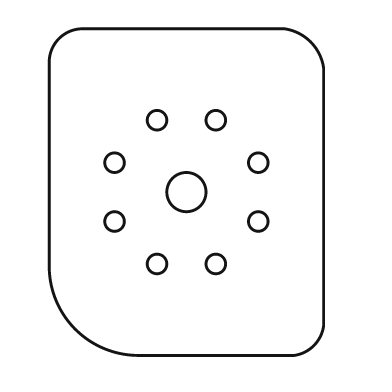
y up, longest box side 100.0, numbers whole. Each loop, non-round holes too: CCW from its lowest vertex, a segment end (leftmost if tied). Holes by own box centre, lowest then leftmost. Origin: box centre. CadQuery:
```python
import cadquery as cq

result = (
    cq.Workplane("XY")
    .moveTo(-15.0, -50.0)
    .lineTo(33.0, -50.0)
    .threePointArc((39.0, -47.0), (42.0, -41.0))
    .lineTo(42.0, 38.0)
    .threePointArc((38.0, 46.0), (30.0, 50.0))
    .lineTo(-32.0, 50.0)
    .threePointArc((-39.0, 47.0), (-42.0, 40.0))
    .lineTo(-42.0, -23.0)
    .threePointArc((-34.0, -42.0), (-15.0, -50.0))
    .close()
    .moveTo(-9.0, -22.0)
    .circle(3.0)
    .moveTo(9.0, -22.0)
    .circle(3.0)
    .moveTo(-22.0, -9.0)
    .circle(3.0)
    .moveTo(22.0, -9.0)
    .circle(3.0)
    .moveTo(0.0, 0.0)
    .circle(6.0)
    .moveTo(-22.0, 9.0)
    .circle(3.0)
    .moveTo(22.0, 9.0)
    .circle(3.0)
    .moveTo(-9.0, 22.0)
    .circle(3.0)
    .moveTo(9.0, 22.0)
    .circle(3.0)
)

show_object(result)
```